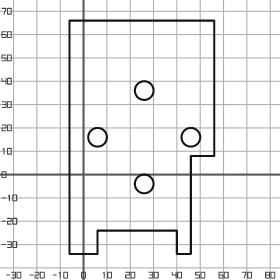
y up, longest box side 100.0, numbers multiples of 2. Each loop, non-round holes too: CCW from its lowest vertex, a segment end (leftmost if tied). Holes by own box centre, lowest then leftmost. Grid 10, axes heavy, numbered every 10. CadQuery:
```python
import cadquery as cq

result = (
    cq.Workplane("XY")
    .moveTo(-6.0, -34.0)
    .lineTo(6.0, -34.0)
    .lineTo(6.0, -24.0)
    .lineTo(40.0, -24.0)
    .lineTo(40.0, -34.0)
    .lineTo(46.0, -34.0)
    .lineTo(46.0, 8.0)
    .lineTo(56.0, 8.0)
    .lineTo(56.0, 66.0)
    .lineTo(-6.0, 66.0)
    .close()
    .moveTo(26.0, -4.0)
    .circle(4.0)
    .moveTo(6.0, 16.0)
    .circle(4.0)
    .moveTo(46.0, 16.0)
    .circle(4.0)
    .moveTo(26.0, 36.0)
    .circle(4.0)
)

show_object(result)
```